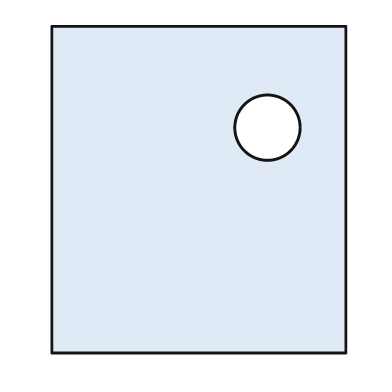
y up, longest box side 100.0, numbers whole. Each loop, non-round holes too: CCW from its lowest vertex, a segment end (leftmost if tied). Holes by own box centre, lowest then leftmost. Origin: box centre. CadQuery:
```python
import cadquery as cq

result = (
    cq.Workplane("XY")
    .moveTo(-45.0, -50.0)
    .lineTo(45.0, -50.0)
    .lineTo(45.0, 50.0)
    .lineTo(-45.0, 50.0)
    .close()
    .moveTo(21.0, 19.0)
    .circle(10.0)
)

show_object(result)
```